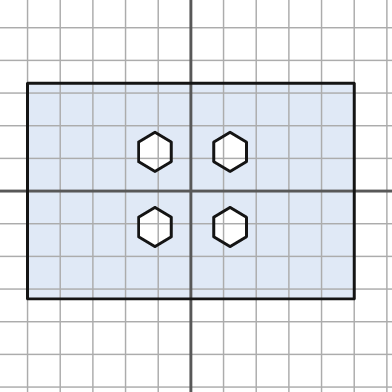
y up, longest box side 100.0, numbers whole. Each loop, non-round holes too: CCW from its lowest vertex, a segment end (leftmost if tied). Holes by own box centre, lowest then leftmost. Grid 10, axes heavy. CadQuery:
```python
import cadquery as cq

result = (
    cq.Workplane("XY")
    .moveTo(-50.0, -33.0)
    .lineTo(50.0, -33.0)
    .lineTo(50.0, 33.0)
    .lineTo(-50.0, 33.0)
    .close()
    .moveTo(-11.0, -17.0)
    .lineTo(-6.0, -14.0)
    .lineTo(-6.0, -8.0)
    .lineTo(-11.0, -5.0)
    .lineTo(-16.0, -8.0)
    .lineTo(-16.0, -14.0)
    .close()
    .moveTo(12.0, -17.0)
    .lineTo(17.0, -14.0)
    .lineTo(17.0, -8.0)
    .lineTo(12.0, -5.0)
    .lineTo(7.0, -8.0)
    .lineTo(7.0, -14.0)
    .close()
    .moveTo(-11.0, 6.0)
    .lineTo(-6.0, 9.0)
    .lineTo(-6.0, 15.0)
    .lineTo(-11.0, 18.0)
    .lineTo(-16.0, 15.0)
    .lineTo(-16.0, 9.0)
    .close()
    .moveTo(12.0, 6.0)
    .lineTo(17.0, 9.0)
    .lineTo(17.0, 15.0)
    .lineTo(12.0, 18.0)
    .lineTo(7.0, 15.0)
    .lineTo(7.0, 9.0)
    .close()
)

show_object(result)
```